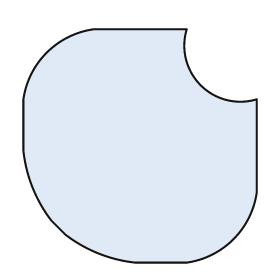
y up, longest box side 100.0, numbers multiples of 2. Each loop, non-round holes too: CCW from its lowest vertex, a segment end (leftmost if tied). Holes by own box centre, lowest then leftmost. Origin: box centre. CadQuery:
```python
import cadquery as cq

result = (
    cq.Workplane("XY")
    .moveTo(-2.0, -50.0)
    .lineTo(20.0, -50.0)
    .threePointArc((40.0, -40.0), (50.0, -20.0))
    .lineTo(50.0, 20.0)
    .threePointArc((26.0, 26.0), (20.0, 50.0))
    .lineTo(-20.0, 50.0)
    .threePointArc((-40.0, 40.0), (-50.0, 20.0))
    .lineTo(-50.0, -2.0)
    .threePointArc((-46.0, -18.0), (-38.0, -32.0))
    .lineTo(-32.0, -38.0)
    .threePointArc((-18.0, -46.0), (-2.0, -50.0))
    .close()
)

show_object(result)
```